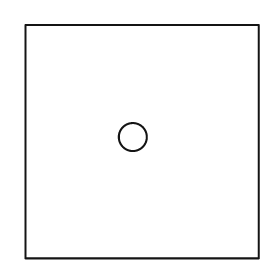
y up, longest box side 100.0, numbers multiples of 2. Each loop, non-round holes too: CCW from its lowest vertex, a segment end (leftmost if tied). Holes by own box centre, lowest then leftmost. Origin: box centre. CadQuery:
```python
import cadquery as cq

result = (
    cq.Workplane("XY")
    .moveTo(-50.0, -50.0)
    .lineTo(50.0, -50.0)
    .lineTo(50.0, 50.0)
    .lineTo(-50.0, 50.0)
    .close()
    .moveTo(-4.0, 2.0)
    .circle(6.0)
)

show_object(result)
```